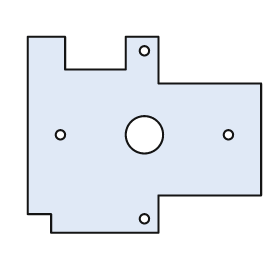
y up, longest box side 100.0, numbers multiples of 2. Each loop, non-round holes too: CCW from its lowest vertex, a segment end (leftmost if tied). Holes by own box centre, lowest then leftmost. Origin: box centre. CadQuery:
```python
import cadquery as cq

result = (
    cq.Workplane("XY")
    .moveTo(-40.0, -42.0)
    .lineTo(6.0, -42.0)
    .lineTo(6.0, -26.0)
    .lineTo(50.0, -26.0)
    .lineTo(50.0, 22.0)
    .lineTo(6.0, 22.0)
    .lineTo(6.0, 42.0)
    .lineTo(-8.0, 42.0)
    .lineTo(-8.0, 28.0)
    .lineTo(-34.0, 28.0)
    .lineTo(-34.0, 42.0)
    .lineTo(-50.0, 42.0)
    .lineTo(-50.0, -34.0)
    .lineTo(-40.0, -34.0)
    .close()
    .moveTo(0.0, -36.0)
    .circle(2.0)
    .moveTo(-36.0, 0.0)
    .circle(2.0)
    .moveTo(0.0, 0.0)
    .circle(8.0)
    .moveTo(36.0, 0.0)
    .circle(2.0)
    .moveTo(0.0, 36.0)
    .circle(2.0)
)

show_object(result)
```